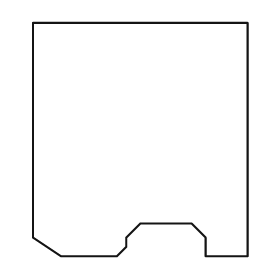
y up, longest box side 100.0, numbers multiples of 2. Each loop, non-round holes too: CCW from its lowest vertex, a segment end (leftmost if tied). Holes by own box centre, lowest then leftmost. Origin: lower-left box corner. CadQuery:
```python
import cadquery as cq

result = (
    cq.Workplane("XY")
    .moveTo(12.0, 0.0)
    .lineTo(36.0, 0.0)
    .lineTo(40.0, 4.0)
    .lineTo(40.0, 8.0)
    .lineTo(46.0, 14.0)
    .lineTo(68.0, 14.0)
    .lineTo(74.0, 8.0)
    .lineTo(74.0, 0.0)
    .lineTo(92.0, 0.0)
    .lineTo(92.0, 100.0)
    .lineTo(0.0, 100.0)
    .lineTo(0.0, 8.0)
    .close()
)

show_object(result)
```